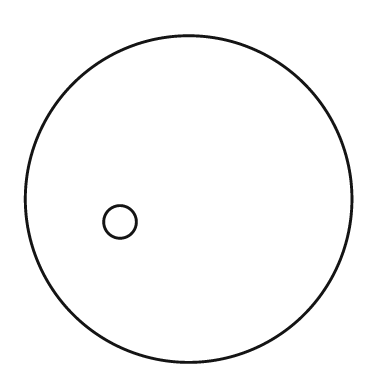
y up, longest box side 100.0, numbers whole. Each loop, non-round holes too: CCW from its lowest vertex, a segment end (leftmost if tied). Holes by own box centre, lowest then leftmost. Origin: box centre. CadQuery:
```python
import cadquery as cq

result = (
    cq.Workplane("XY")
    .moveTo(0.0, 0.0)
    .circle(50.0)
    .moveTo(-21.0, -7.0)
    .circle(5.0)
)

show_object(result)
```